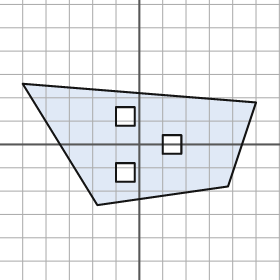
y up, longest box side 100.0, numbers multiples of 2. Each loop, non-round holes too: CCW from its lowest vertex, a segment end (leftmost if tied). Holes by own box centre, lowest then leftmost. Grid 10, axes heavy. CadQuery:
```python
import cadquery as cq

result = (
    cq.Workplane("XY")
    .moveTo(-18.0, -26.0)
    .lineTo(38.0, -18.0)
    .lineTo(50.0, 18.0)
    .lineTo(-50.0, 26.0)
    .close()
    .moveTo(-10.0, -16.0)
    .lineTo(-2.0, -16.0)
    .lineTo(-2.0, -8.0)
    .lineTo(-10.0, -8.0)
    .close()
    .moveTo(10.0, -4.0)
    .lineTo(18.0, -4.0)
    .lineTo(18.0, 4.0)
    .lineTo(10.0, 4.0)
    .close()
    .moveTo(-10.0, 8.0)
    .lineTo(-2.0, 8.0)
    .lineTo(-2.0, 16.0)
    .lineTo(-10.0, 16.0)
    .close()
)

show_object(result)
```